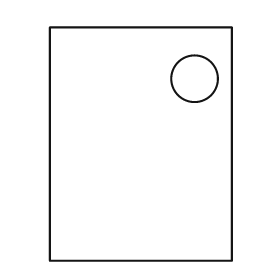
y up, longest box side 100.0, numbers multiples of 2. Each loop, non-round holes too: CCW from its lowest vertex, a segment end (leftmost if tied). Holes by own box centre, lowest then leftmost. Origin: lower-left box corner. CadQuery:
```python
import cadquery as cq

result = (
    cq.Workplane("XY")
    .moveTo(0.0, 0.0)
    .lineTo(78.0, 0.0)
    .lineTo(78.0, 100.0)
    .lineTo(0.0, 100.0)
    .close()
    .moveTo(62.0, 78.0)
    .circle(10.0)
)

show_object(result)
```